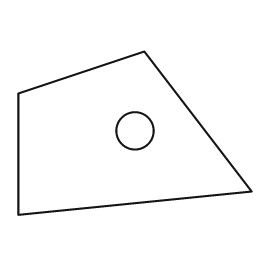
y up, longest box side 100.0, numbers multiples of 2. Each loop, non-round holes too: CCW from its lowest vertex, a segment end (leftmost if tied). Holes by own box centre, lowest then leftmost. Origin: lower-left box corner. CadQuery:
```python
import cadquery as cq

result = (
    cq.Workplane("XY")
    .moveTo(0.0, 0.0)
    .lineTo(100.0, 10.0)
    .lineTo(54.0, 70.0)
    .lineTo(0.0, 52.0)
    .close()
    .moveTo(50.0, 36.0)
    .circle(8.0)
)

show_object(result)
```